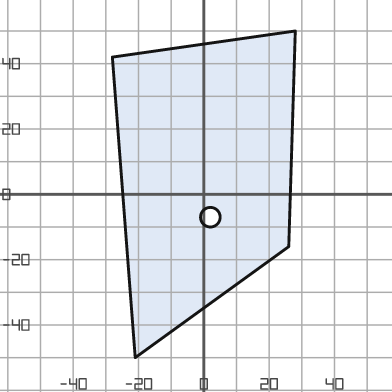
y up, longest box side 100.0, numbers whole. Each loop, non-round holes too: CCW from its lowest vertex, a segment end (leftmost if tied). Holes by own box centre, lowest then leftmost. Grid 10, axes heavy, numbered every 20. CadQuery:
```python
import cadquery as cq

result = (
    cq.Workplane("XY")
    .moveTo(-21.0, -50.0)
    .lineTo(26.0, -16.0)
    .lineTo(28.0, 50.0)
    .lineTo(-28.0, 42.0)
    .close()
    .moveTo(2.0, -7.0)
    .circle(3.0)
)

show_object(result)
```